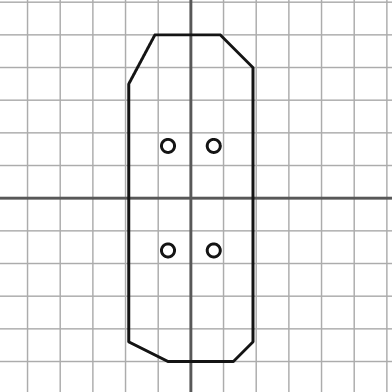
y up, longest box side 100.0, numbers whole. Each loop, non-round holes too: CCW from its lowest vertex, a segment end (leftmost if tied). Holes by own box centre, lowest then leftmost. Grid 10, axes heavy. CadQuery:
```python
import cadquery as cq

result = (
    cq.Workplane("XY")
    .moveTo(-7.0, -50.0)
    .lineTo(13.0, -50.0)
    .lineTo(19.0, -44.0)
    .lineTo(19.0, 40.0)
    .lineTo(9.0, 50.0)
    .lineTo(-11.0, 50.0)
    .lineTo(-19.0, 35.0)
    .lineTo(-19.0, -44.0)
    .close()
    .moveTo(-7.0, -16.0)
    .circle(2.0)
    .moveTo(7.0, -16.0)
    .circle(2.0)
    .moveTo(-7.0, 16.0)
    .circle(2.0)
    .moveTo(7.0, 16.0)
    .circle(2.0)
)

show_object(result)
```